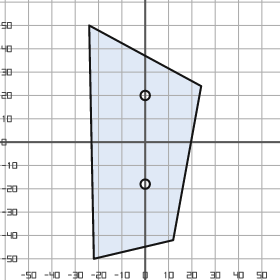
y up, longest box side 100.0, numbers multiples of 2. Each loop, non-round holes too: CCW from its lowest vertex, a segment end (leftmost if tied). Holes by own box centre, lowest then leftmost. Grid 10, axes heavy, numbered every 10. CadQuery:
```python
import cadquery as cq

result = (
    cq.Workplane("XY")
    .moveTo(-22.0, -50.0)
    .lineTo(12.0, -42.0)
    .lineTo(24.0, 24.0)
    .lineTo(-24.0, 50.0)
    .close()
    .moveTo(0.0, -18.0)
    .circle(2.0)
    .moveTo(0.0, 20.0)
    .circle(2.0)
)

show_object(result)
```